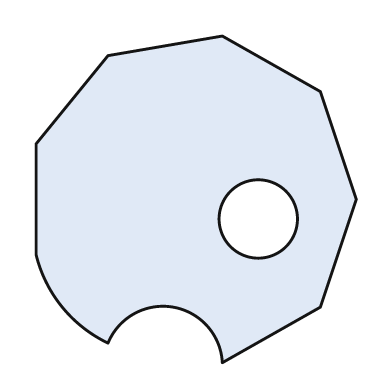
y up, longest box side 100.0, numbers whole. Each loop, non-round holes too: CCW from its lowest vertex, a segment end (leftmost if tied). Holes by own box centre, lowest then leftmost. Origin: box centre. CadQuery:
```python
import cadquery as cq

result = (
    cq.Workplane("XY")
    .moveTo(8.0, -50.0)
    .lineTo(38.0, -33.0)
    .lineTo(49.0, 0.0)
    .lineTo(38.0, 33.0)
    .lineTo(8.0, 50.0)
    .lineTo(-27.0, 44.0)
    .lineTo(-49.0, 17.0)
    .lineTo(-49.0, -17.0)
    .threePointArc((-41.0, -33.0), (-27.0, -44.0))
    .threePointArc((-7.0, -33.0), (8.0, -50.0))
    .close()
    .moveTo(19.0, -6.0)
    .circle(12.0)
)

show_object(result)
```